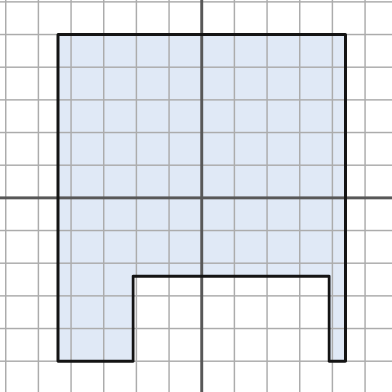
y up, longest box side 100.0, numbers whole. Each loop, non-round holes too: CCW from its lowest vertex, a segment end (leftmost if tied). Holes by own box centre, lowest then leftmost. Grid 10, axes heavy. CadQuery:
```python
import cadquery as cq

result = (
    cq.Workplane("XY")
    .moveTo(-44.0, -50.0)
    .lineTo(-21.0, -50.0)
    .lineTo(-21.0, -24.0)
    .lineTo(39.0, -24.0)
    .lineTo(39.0, -50.0)
    .lineTo(44.0, -50.0)
    .lineTo(44.0, 50.0)
    .lineTo(-44.0, 50.0)
    .close()
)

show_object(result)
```